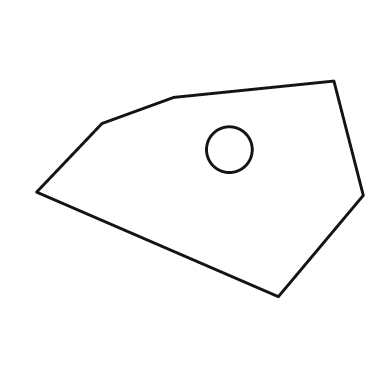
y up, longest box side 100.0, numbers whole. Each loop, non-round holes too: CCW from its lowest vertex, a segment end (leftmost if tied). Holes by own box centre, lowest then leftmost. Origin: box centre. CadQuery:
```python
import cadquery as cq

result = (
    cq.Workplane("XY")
    .moveTo(24.0, -33.0)
    .lineTo(50.0, -2.0)
    .lineTo(41.0, 33.0)
    .lineTo(-8.0, 28.0)
    .lineTo(-30.0, 20.0)
    .lineTo(-50.0, -1.0)
    .close()
    .moveTo(9.0, 12.0)
    .circle(7.0)
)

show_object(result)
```